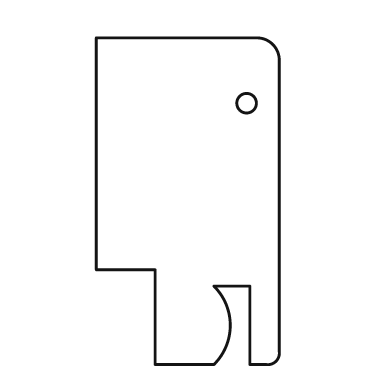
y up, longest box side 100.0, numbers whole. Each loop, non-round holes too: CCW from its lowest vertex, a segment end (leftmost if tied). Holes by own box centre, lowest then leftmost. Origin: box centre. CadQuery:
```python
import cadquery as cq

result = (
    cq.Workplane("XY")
    .moveTo(-10.0, -50.0)
    .lineTo(8.0, -50.0)
    .threePointArc((13.0, -38.0), (8.0, -26.0))
    .lineTo(19.0, -26.0)
    .lineTo(19.0, -50.0)
    .lineTo(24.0, -50.0)
    .threePointArc((27.0, -49.0), (28.0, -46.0))
    .lineTo(28.0, 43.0)
    .threePointArc((26.0, 48.0), (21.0, 50.0))
    .lineTo(-28.0, 50.0)
    .lineTo(-28.0, -21.0)
    .lineTo(-10.0, -21.0)
    .close()
    .moveTo(18.0, 30.0)
    .circle(3.0)
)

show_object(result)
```